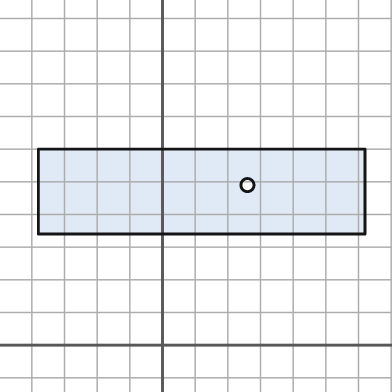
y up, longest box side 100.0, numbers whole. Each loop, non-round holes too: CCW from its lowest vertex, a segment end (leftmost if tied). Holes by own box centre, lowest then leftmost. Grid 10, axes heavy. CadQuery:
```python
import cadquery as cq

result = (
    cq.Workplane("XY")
    .moveTo(-38.0, 34.0)
    .lineTo(62.0, 34.0)
    .lineTo(62.0, 60.0)
    .lineTo(-38.0, 60.0)
    .close()
    .moveTo(26.0, 49.0)
    .circle(2.0)
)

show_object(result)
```